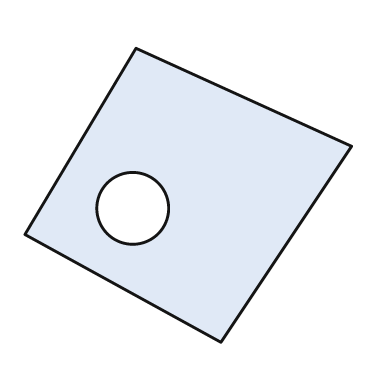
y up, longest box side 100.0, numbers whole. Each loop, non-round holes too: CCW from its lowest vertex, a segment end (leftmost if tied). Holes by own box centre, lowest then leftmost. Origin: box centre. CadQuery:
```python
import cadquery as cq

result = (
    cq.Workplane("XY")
    .moveTo(10.0, -45.0)
    .lineTo(50.0, 15.0)
    .lineTo(-16.0, 45.0)
    .lineTo(-50.0, -12.0)
    .close()
    .moveTo(-17.0, -4.0)
    .circle(11.0)
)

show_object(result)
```